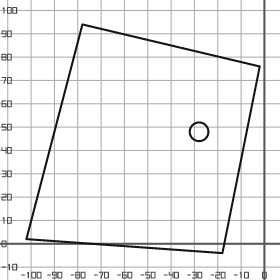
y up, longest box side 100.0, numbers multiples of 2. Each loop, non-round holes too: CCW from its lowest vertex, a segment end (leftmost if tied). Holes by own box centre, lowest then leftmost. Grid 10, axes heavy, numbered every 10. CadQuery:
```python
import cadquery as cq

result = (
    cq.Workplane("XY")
    .moveTo(-18.0, -4.0)
    .lineTo(-2.0, 76.0)
    .lineTo(-78.0, 94.0)
    .lineTo(-102.0, 2.0)
    .close()
    .moveTo(-28.0, 48.0)
    .circle(4.0)
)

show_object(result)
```